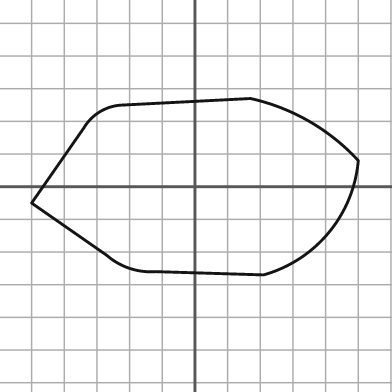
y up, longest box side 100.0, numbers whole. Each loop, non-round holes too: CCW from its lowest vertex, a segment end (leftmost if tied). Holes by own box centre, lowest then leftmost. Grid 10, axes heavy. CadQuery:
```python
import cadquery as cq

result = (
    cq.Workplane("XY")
    .moveTo(21.0, -27.0)
    .threePointArc((41.0, -14.0), (50.0, 8.0))
    .threePointArc((35.0, 20.0), (17.0, 27.0))
    .lineTo(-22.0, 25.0)
    .threePointArc((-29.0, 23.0), (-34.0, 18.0))
    .lineTo(-50.0, -5.0)
    .lineTo(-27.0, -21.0)
    .threePointArc((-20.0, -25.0), (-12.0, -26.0))
    .close()
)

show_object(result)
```